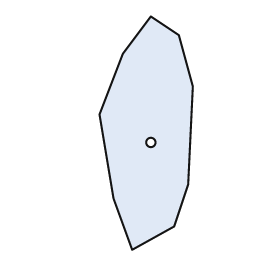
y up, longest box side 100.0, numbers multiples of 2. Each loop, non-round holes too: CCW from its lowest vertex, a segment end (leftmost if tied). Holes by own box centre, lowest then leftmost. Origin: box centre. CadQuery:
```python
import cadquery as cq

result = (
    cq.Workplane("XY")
    .moveTo(-6.0, -50.0)
    .lineTo(12.0, -40.0)
    .lineTo(18.0, -22.0)
    .lineTo(20.0, 20.0)
    .lineTo(14.0, 42.0)
    .lineTo(2.0, 50.0)
    .lineTo(-10.0, 34.0)
    .lineTo(-20.0, 8.0)
    .lineTo(-14.0, -28.0)
    .close()
    .moveTo(2.0, -4.0)
    .circle(2.0)
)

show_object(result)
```